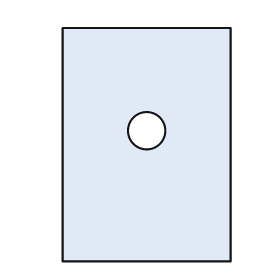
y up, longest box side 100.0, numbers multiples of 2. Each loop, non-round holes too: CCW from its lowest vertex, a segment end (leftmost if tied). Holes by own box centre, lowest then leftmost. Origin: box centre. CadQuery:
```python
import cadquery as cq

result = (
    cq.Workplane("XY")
    .moveTo(-36.0, -50.0)
    .lineTo(36.0, -50.0)
    .lineTo(36.0, 50.0)
    .lineTo(-36.0, 50.0)
    .close()
    .moveTo(0.0, 6.0)
    .circle(8.0)
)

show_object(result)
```